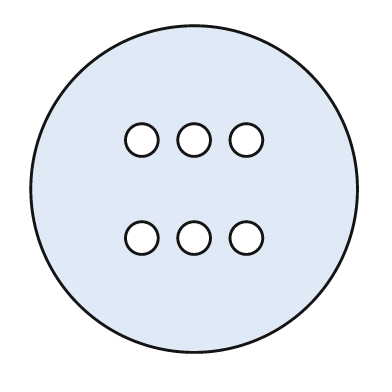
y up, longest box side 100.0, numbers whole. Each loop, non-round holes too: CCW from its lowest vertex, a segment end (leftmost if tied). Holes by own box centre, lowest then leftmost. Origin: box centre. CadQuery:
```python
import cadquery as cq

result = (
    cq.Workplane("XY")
    .moveTo(0.0, 0.0)
    .circle(50.0)
    .moveTo(-16.0, -15.0)
    .circle(5.0)
    .moveTo(0.0, -15.0)
    .circle(5.0)
    .moveTo(16.0, -15.0)
    .circle(5.0)
    .moveTo(-16.0, 15.0)
    .circle(5.0)
    .moveTo(0.0, 15.0)
    .circle(5.0)
    .moveTo(16.0, 15.0)
    .circle(5.0)
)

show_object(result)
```